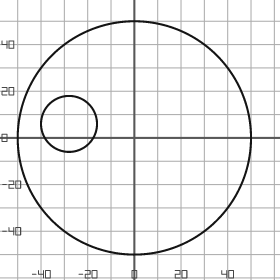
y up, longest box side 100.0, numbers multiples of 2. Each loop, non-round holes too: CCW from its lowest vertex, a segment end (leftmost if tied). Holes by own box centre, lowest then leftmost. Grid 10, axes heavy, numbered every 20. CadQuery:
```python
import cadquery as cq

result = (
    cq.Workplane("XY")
    .moveTo(0.0, 0.0)
    .circle(50.0)
    .moveTo(-28.0, 6.0)
    .circle(12.0)
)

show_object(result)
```